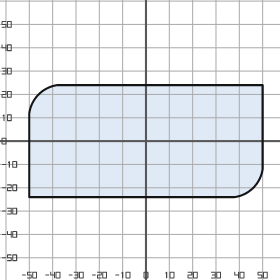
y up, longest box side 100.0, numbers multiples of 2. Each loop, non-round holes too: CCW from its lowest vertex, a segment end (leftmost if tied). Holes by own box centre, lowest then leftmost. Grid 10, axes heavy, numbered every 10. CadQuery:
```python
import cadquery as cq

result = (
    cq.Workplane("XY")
    .moveTo(-50.0, -24.0)
    .lineTo(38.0, -24.0)
    .threePointArc((46.0, -20.0), (50.0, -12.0))
    .lineTo(50.0, 24.0)
    .lineTo(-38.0, 24.0)
    .threePointArc((-46.0, 20.0), (-50.0, 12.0))
    .close()
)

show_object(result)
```